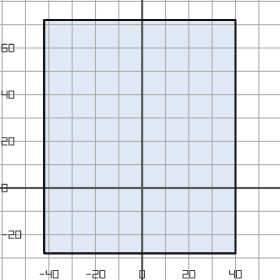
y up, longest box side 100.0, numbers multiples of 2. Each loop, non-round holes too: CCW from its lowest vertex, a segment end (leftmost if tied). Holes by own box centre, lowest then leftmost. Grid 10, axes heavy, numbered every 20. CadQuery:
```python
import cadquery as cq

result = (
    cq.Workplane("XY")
    .moveTo(-42.0, -28.0)
    .lineTo(40.0, -28.0)
    .lineTo(40.0, 72.0)
    .lineTo(-42.0, 72.0)
    .close()
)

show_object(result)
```